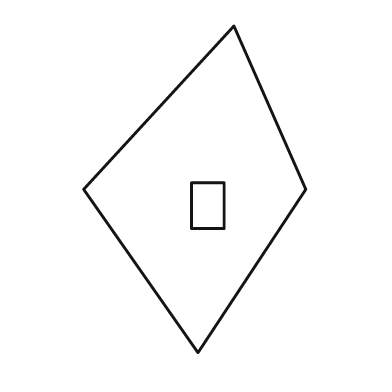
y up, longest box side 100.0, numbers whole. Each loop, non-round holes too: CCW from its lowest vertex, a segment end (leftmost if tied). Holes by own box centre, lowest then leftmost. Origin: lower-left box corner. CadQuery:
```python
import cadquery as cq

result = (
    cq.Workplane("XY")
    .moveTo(35.0, 0.0)
    .lineTo(68.0, 50.0)
    .lineTo(46.0, 100.0)
    .lineTo(0.0, 50.0)
    .close()
    .moveTo(33.0, 38.0)
    .lineTo(43.0, 38.0)
    .lineTo(43.0, 52.0)
    .lineTo(33.0, 52.0)
    .close()
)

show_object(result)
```